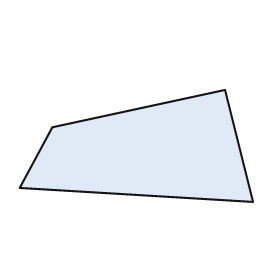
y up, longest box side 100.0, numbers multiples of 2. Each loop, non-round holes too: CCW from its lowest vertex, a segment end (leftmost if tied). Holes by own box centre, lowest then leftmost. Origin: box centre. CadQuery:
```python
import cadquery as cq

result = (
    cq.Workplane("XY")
    .moveTo(50.0, -24.0)
    .lineTo(38.0, 24.0)
    .lineTo(-36.0, 8.0)
    .lineTo(-50.0, -18.0)
    .close()
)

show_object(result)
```